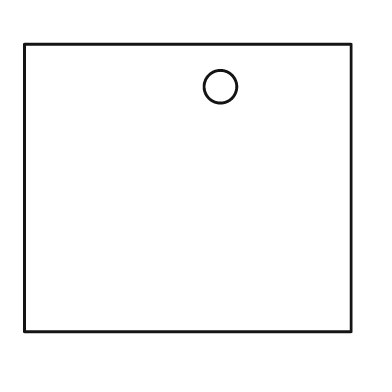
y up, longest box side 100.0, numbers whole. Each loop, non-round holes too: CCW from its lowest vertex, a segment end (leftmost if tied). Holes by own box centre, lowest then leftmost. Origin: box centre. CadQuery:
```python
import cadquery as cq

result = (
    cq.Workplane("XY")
    .moveTo(-50.0, -44.0)
    .lineTo(50.0, -44.0)
    .lineTo(50.0, 44.0)
    .lineTo(-50.0, 44.0)
    .close()
    .moveTo(10.0, 31.0)
    .circle(5.0)
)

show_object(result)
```